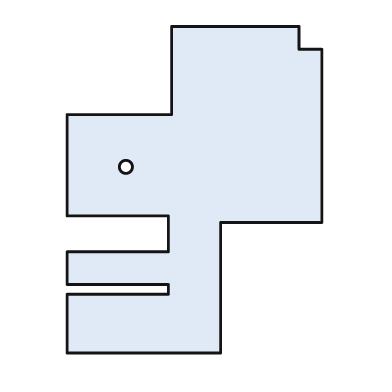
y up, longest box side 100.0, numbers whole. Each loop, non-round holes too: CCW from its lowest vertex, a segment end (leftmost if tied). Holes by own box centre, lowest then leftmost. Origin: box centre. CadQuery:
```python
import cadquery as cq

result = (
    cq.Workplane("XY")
    .moveTo(-39.0, -50.0)
    .lineTo(8.0, -50.0)
    .lineTo(8.0, -10.0)
    .lineTo(39.0, -10.0)
    .lineTo(39.0, 43.0)
    .lineTo(32.0, 43.0)
    .lineTo(32.0, 50.0)
    .lineTo(-7.0, 50.0)
    .lineTo(-7.0, 23.0)
    .lineTo(-39.0, 23.0)
    .lineTo(-39.0, -8.0)
    .lineTo(-8.0, -8.0)
    .lineTo(-8.0, -19.0)
    .lineTo(-39.0, -19.0)
    .lineTo(-39.0, -29.0)
    .lineTo(-8.0, -29.0)
    .lineTo(-8.0, -32.0)
    .lineTo(-39.0, -32.0)
    .close()
    .moveTo(-21.0, 7.0)
    .circle(2.0)
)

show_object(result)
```